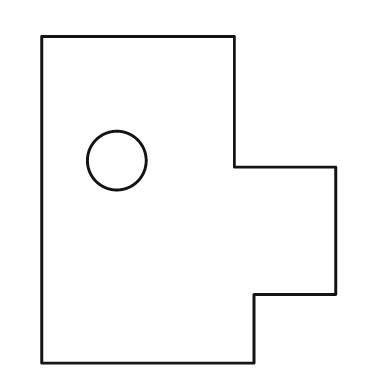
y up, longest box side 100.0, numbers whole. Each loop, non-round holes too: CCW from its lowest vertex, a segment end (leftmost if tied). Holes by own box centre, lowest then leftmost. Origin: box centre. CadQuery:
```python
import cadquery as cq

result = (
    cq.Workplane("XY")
    .moveTo(-45.0, -50.0)
    .lineTo(20.0, -50.0)
    .lineTo(20.0, -29.0)
    .lineTo(45.0, -29.0)
    .lineTo(45.0, 10.0)
    .lineTo(14.0, 10.0)
    .lineTo(14.0, 50.0)
    .lineTo(-45.0, 50.0)
    .close()
    .moveTo(-22.0, 12.0)
    .circle(9.0)
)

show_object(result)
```